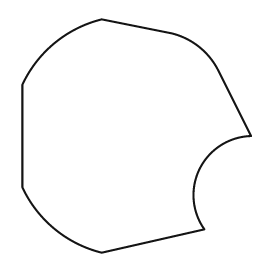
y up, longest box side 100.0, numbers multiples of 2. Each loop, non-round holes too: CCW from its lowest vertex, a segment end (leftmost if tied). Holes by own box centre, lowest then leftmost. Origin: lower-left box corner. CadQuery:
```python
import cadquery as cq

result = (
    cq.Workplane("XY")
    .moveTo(34.0, 0.0)
    .lineTo(78.0, 10.0)
    .threePointArc((76.0, 36.0), (98.0, 50.0))
    .lineTo(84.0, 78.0)
    .threePointArc((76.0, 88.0), (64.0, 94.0))
    .lineTo(34.0, 100.0)
    .threePointArc((14.0, 90.0), (0.0, 72.0))
    .lineTo(0.0, 28.0)
    .threePointArc((14.0, 10.0), (34.0, 0.0))
    .close()
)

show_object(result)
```